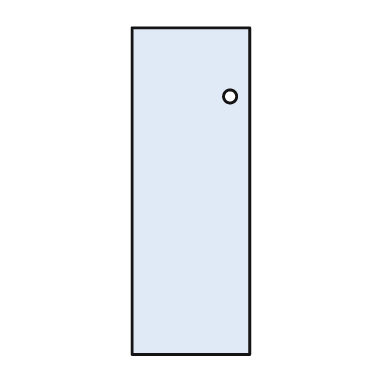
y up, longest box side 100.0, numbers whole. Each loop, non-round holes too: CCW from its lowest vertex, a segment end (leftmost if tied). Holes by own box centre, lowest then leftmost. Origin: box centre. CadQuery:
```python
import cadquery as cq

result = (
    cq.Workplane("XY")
    .moveTo(-18.0, -50.0)
    .lineTo(18.0, -50.0)
    .lineTo(18.0, 50.0)
    .lineTo(-18.0, 50.0)
    .close()
    .moveTo(12.0, 29.0)
    .circle(2.0)
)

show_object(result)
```